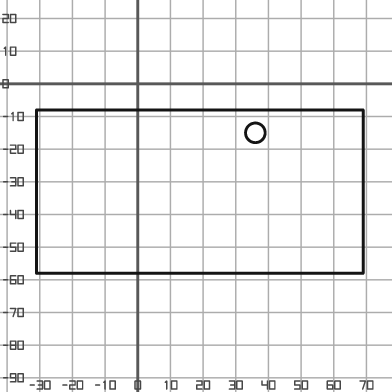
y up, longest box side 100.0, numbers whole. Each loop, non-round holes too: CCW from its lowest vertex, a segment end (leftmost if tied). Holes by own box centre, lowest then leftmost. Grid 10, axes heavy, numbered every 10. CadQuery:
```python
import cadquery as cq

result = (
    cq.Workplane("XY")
    .moveTo(-31.0, -58.0)
    .lineTo(69.0, -58.0)
    .lineTo(69.0, -8.0)
    .lineTo(-31.0, -8.0)
    .close()
    .moveTo(36.0, -15.0)
    .circle(3.0)
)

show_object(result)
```